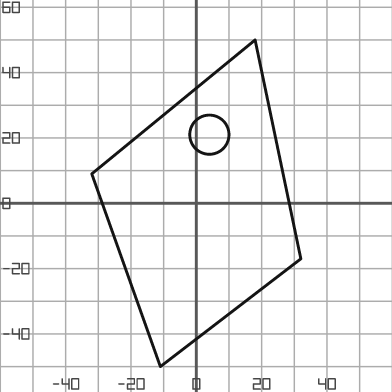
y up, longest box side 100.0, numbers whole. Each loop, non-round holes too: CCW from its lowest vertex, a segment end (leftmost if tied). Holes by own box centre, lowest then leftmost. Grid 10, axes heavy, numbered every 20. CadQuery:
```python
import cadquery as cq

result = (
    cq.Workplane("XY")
    .moveTo(-11.0, -50.0)
    .lineTo(32.0, -17.0)
    .lineTo(18.0, 50.0)
    .lineTo(-32.0, 9.0)
    .close()
    .moveTo(4.0, 21.0)
    .circle(6.0)
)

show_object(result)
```